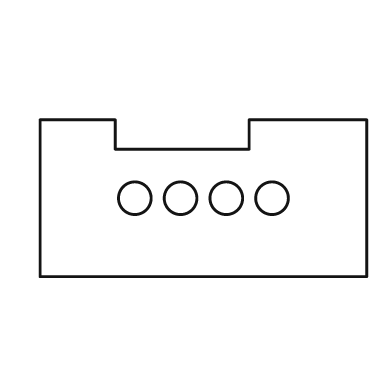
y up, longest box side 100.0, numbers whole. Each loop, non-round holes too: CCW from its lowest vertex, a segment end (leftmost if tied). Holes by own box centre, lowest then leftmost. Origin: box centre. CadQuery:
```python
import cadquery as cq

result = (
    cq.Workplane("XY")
    .moveTo(-50.0, -24.0)
    .lineTo(50.0, -24.0)
    .lineTo(50.0, 24.0)
    .lineTo(14.0, 24.0)
    .lineTo(14.0, 15.0)
    .lineTo(-27.0, 15.0)
    .lineTo(-27.0, 24.0)
    .lineTo(-50.0, 24.0)
    .close()
    .moveTo(-21.0, 0.0)
    .circle(5.0)
    .moveTo(-7.0, 0.0)
    .circle(5.0)
    .moveTo(7.0, 0.0)
    .circle(5.0)
    .moveTo(21.0, 0.0)
    .circle(5.0)
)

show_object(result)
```